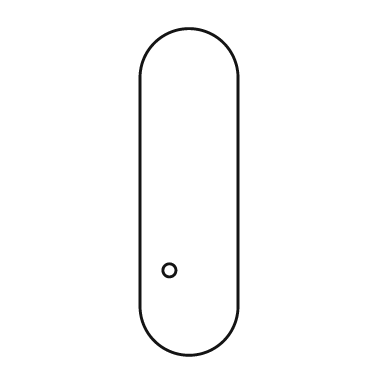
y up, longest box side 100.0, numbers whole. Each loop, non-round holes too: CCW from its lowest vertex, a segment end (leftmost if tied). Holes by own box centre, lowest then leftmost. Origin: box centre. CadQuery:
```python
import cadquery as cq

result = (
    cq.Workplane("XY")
    .moveTo(-15.0, -35.0)
    .threePointArc((0.0, -50.0), (15.0, -35.0))
    .lineTo(15.0, 35.0)
    .threePointArc((0.0, 50.0), (-15.0, 35.0))
    .close()
    .moveTo(-6.0, -24.0)
    .circle(2.0)
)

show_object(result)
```